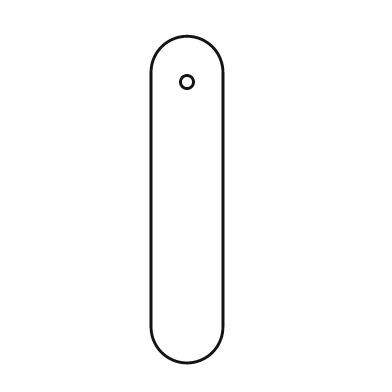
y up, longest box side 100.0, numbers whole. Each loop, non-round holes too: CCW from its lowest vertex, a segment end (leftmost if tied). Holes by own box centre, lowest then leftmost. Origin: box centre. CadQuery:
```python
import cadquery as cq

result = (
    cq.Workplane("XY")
    .moveTo(-11.0, -39.0)
    .threePointArc((0.0, -50.0), (11.0, -39.0))
    .lineTo(11.0, 39.0)
    .threePointArc((0.0, 50.0), (-11.0, 39.0))
    .close()
    .moveTo(0.0, 36.0)
    .circle(2.0)
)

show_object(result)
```